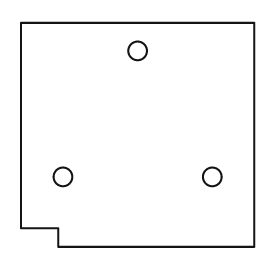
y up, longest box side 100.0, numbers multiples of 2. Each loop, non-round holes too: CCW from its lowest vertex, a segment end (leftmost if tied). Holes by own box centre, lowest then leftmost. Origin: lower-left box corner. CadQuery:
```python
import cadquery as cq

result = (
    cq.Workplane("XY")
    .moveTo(16.0, 0.0)
    .lineTo(100.0, 0.0)
    .lineTo(100.0, 96.0)
    .lineTo(0.0, 96.0)
    .lineTo(0.0, 8.0)
    .lineTo(16.0, 8.0)
    .close()
    .moveTo(18.0, 30.0)
    .circle(4.0)
    .moveTo(82.0, 30.0)
    .circle(4.0)
    .moveTo(50.0, 84.0)
    .circle(4.0)
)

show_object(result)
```